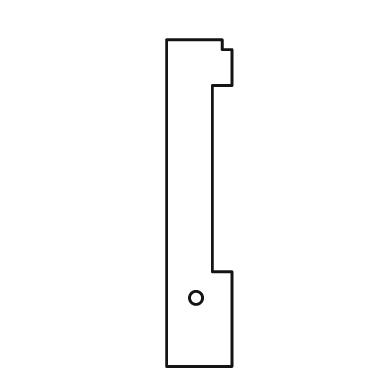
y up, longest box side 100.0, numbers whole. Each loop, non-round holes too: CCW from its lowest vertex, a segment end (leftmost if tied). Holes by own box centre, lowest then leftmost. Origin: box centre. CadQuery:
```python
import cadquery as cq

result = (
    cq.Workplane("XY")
    .moveTo(-10.0, -50.0)
    .lineTo(10.0, -50.0)
    .lineTo(10.0, -21.0)
    .lineTo(4.0, -21.0)
    .lineTo(4.0, 36.0)
    .lineTo(10.0, 36.0)
    .lineTo(10.0, 47.0)
    .lineTo(7.0, 47.0)
    .lineTo(7.0, 50.0)
    .lineTo(-10.0, 50.0)
    .close()
    .moveTo(-1.0, -29.0)
    .circle(2.0)
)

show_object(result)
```